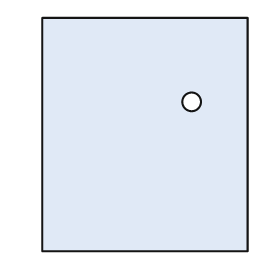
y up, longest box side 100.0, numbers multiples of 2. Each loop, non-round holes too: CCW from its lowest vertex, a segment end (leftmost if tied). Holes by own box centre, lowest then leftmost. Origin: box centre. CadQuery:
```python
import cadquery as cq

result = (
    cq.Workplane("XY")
    .moveTo(-44.0, -50.0)
    .lineTo(44.0, -50.0)
    .lineTo(44.0, 50.0)
    .lineTo(-44.0, 50.0)
    .close()
    .moveTo(20.0, 14.0)
    .circle(4.0)
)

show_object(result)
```